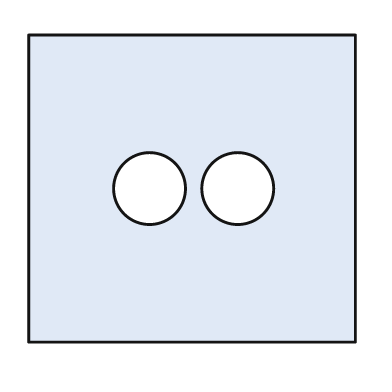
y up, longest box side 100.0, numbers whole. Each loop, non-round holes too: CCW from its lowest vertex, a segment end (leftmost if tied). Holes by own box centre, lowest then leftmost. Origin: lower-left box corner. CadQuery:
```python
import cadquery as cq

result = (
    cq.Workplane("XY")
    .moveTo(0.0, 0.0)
    .lineTo(100.0, 0.0)
    .lineTo(100.0, 94.0)
    .lineTo(0.0, 94.0)
    .close()
    .moveTo(37.0, 47.0)
    .circle(11.0)
    .moveTo(64.0, 47.0)
    .circle(11.0)
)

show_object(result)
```